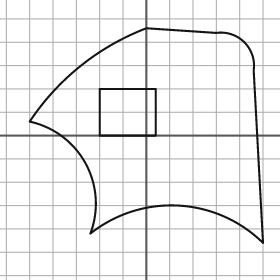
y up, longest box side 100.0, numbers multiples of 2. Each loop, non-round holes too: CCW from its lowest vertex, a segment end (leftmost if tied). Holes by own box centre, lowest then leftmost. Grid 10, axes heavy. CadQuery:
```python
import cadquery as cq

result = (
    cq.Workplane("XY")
    .moveTo(50.0, -46.0)
    .lineTo(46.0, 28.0)
    .threePointArc((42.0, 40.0), (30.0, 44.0))
    .lineTo(0.0, 46.0)
    .threePointArc((-28.0, 30.0), (-50.0, 6.0))
    .threePointArc((-26.0, -12.0), (-24.0, -42.0))
    .threePointArc((14.0, -30.0), (50.0, -46.0))
    .close()
    .moveTo(-20.0, 0.0)
    .lineTo(4.0, 0.0)
    .lineTo(4.0, 20.0)
    .lineTo(-20.0, 20.0)
    .close()
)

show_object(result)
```